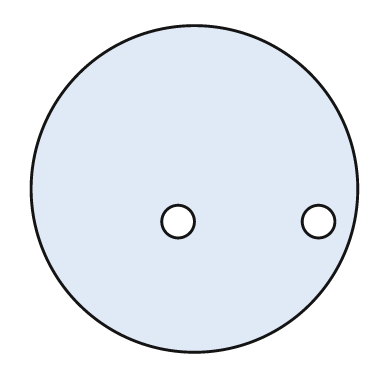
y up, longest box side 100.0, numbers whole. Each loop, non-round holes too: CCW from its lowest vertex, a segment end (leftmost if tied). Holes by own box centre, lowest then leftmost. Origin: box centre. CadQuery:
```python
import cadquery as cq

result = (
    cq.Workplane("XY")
    .moveTo(0.0, 0.0)
    .circle(50.0)
    .moveTo(-5.0, -10.0)
    .circle(5.0)
    .moveTo(38.0, -10.0)
    .circle(5.0)
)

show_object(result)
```